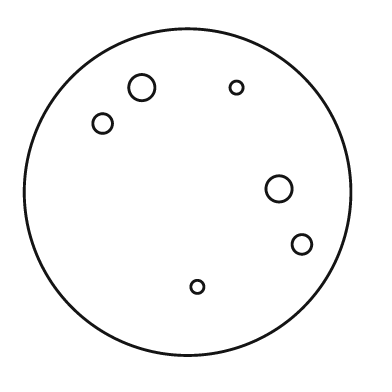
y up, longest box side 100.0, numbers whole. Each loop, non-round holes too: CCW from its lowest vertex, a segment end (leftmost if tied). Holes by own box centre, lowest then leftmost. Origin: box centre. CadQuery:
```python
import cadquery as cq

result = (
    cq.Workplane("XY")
    .moveTo(0.0, 0.0)
    .circle(50.0)
    .moveTo(3.0, -29.0)
    .circle(2.0)
    .moveTo(35.0, -16.0)
    .circle(3.0)
    .moveTo(28.0, 1.0)
    .circle(4.0)
    .moveTo(-26.0, 21.0)
    .circle(3.0)
    .moveTo(-14.0, 32.0)
    .circle(4.0)
    .moveTo(15.0, 32.0)
    .circle(2.0)
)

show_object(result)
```